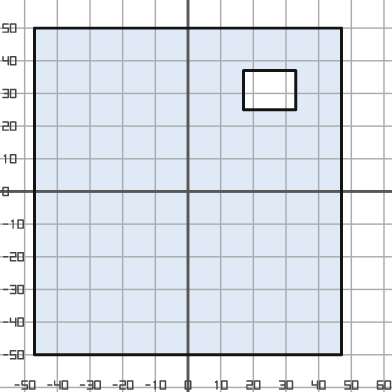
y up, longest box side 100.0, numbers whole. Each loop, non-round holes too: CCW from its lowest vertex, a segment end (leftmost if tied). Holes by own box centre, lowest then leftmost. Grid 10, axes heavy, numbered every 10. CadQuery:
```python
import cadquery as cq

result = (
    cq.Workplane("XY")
    .moveTo(-47.0, -50.0)
    .lineTo(47.0, -50.0)
    .lineTo(47.0, 50.0)
    .lineTo(-47.0, 50.0)
    .close()
    .moveTo(17.0, 25.0)
    .lineTo(33.0, 25.0)
    .lineTo(33.0, 37.0)
    .lineTo(17.0, 37.0)
    .close()
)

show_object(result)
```